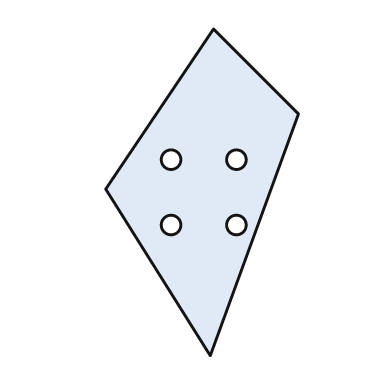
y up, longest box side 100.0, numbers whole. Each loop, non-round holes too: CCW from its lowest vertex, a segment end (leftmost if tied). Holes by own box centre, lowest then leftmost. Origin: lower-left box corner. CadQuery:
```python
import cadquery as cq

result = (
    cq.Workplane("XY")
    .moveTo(32.0, 0.0)
    .lineTo(59.0, 74.0)
    .lineTo(33.0, 100.0)
    .lineTo(0.0, 51.0)
    .close()
    .moveTo(20.0, 40.0)
    .circle(3.0)
    .moveTo(40.0, 40.0)
    .circle(3.0)
    .moveTo(20.0, 60.0)
    .circle(3.0)
    .moveTo(40.0, 60.0)
    .circle(3.0)
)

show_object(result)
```